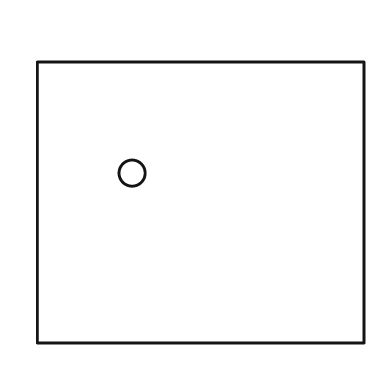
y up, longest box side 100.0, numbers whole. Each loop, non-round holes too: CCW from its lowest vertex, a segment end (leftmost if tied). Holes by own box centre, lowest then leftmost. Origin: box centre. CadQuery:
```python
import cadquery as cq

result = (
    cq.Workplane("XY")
    .moveTo(-50.0, -43.0)
    .lineTo(50.0, -43.0)
    .lineTo(50.0, 43.0)
    .lineTo(-50.0, 43.0)
    .close()
    .moveTo(-21.0, 9.0)
    .circle(4.0)
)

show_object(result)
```